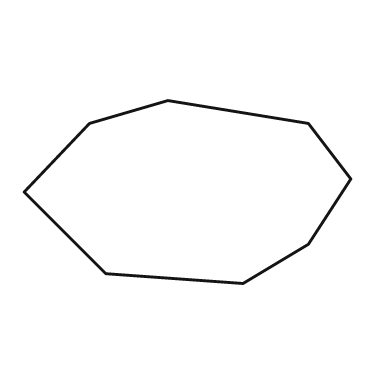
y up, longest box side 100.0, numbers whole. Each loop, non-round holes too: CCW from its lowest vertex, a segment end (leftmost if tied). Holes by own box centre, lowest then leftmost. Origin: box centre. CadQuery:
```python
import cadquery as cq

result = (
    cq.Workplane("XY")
    .moveTo(17.0, -28.0)
    .lineTo(37.0, -16.0)
    .lineTo(50.0, 4.0)
    .lineTo(37.0, 21.0)
    .lineTo(-6.0, 28.0)
    .lineTo(-30.0, 21.0)
    .lineTo(-50.0, 0.0)
    .lineTo(-25.0, -25.0)
    .close()
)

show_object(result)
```